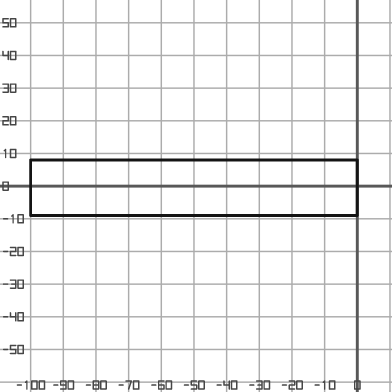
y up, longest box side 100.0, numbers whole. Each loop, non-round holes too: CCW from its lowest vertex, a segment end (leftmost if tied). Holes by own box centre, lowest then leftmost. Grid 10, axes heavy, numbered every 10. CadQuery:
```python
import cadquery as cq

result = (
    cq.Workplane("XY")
    .moveTo(-100.0, -9.0)
    .lineTo(0.0, -9.0)
    .lineTo(0.0, 8.0)
    .lineTo(-100.0, 8.0)
    .close()
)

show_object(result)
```